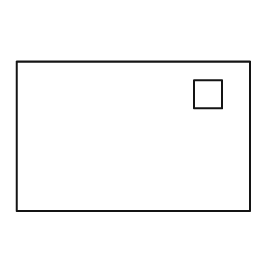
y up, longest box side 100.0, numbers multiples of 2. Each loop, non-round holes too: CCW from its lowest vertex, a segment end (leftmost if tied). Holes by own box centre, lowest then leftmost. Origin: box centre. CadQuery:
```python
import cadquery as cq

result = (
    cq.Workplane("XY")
    .moveTo(-50.0, -32.0)
    .lineTo(50.0, -32.0)
    .lineTo(50.0, 32.0)
    .lineTo(-50.0, 32.0)
    .close()
    .moveTo(26.0, 12.0)
    .lineTo(38.0, 12.0)
    .lineTo(38.0, 24.0)
    .lineTo(26.0, 24.0)
    .close()
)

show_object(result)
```